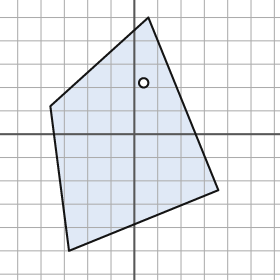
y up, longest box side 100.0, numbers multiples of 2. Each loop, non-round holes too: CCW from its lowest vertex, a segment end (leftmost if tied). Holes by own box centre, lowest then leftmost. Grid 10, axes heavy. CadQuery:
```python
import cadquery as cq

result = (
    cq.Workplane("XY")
    .moveTo(-28.0, -50.0)
    .lineTo(36.0, -24.0)
    .lineTo(6.0, 50.0)
    .lineTo(-36.0, 12.0)
    .close()
    .moveTo(4.0, 22.0)
    .circle(2.0)
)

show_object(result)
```